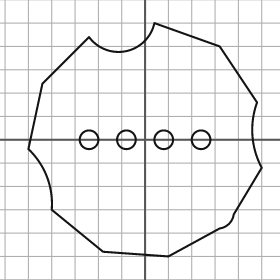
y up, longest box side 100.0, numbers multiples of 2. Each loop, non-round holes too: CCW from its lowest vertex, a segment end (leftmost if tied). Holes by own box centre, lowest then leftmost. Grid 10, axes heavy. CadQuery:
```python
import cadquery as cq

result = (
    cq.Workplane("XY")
    .moveTo(10.0, -50.0)
    .lineTo(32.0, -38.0)
    .threePointArc((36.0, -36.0), (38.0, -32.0))
    .lineTo(50.0, -12.0)
    .threePointArc((46.0, 2.0), (48.0, 16.0))
    .lineTo(32.0, 40.0)
    .lineTo(4.0, 50.0)
    .threePointArc((-8.0, 38.0), (-24.0, 44.0))
    .lineTo(-44.0, 24.0)
    .lineTo(-50.0, -4.0)
    .threePointArc((-42.0, -16.0), (-40.0, -30.0))
    .lineTo(-18.0, -48.0)
    .close()
    .moveTo(-24.0, 0.0)
    .circle(4.0)
    .moveTo(-8.0, 0.0)
    .circle(4.0)
    .moveTo(8.0, 0.0)
    .circle(4.0)
    .moveTo(24.0, 0.0)
    .circle(4.0)
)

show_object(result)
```